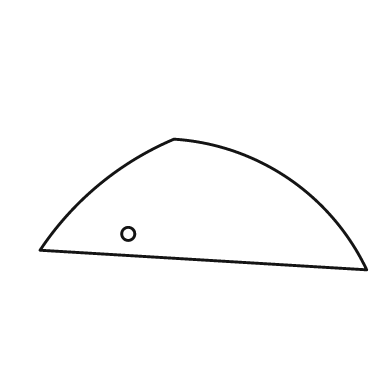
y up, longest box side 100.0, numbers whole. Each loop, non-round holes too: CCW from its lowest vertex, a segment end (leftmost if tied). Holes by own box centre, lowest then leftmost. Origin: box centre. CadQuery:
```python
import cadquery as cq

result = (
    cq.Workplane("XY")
    .moveTo(50.0, -20.0)
    .threePointArc((26.0, 8.0), (-9.0, 20.0))
    .threePointArc((-32.0, 6.0), (-50.0, -14.0))
    .close()
    .moveTo(-23.0, -9.0)
    .circle(2.0)
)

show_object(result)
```